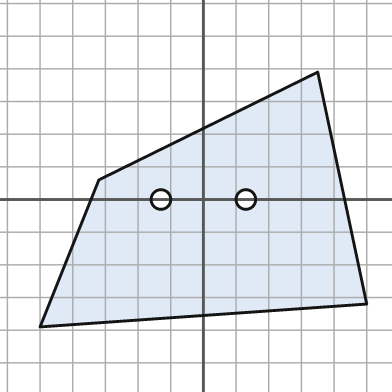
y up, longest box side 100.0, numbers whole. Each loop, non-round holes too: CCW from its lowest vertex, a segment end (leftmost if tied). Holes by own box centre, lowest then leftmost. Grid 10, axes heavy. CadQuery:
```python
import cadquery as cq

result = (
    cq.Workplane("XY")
    .moveTo(-50.0, -39.0)
    .lineTo(50.0, -32.0)
    .lineTo(35.0, 39.0)
    .lineTo(-32.0, 6.0)
    .close()
    .moveTo(-13.0, 0.0)
    .circle(3.0)
    .moveTo(13.0, 0.0)
    .circle(3.0)
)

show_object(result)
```